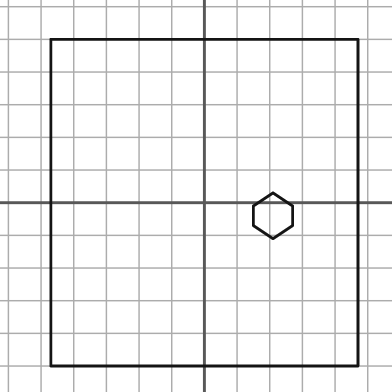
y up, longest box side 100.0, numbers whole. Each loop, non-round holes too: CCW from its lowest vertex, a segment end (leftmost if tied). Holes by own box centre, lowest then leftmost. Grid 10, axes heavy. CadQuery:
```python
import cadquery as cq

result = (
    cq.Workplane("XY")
    .moveTo(-47.0, -50.0)
    .lineTo(47.0, -50.0)
    .lineTo(47.0, 50.0)
    .lineTo(-47.0, 50.0)
    .close()
    .moveTo(21.0, -11.0)
    .lineTo(27.0, -7.0)
    .lineTo(27.0, -1.0)
    .lineTo(21.0, 3.0)
    .lineTo(15.0, -1.0)
    .lineTo(15.0, -7.0)
    .close()
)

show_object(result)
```